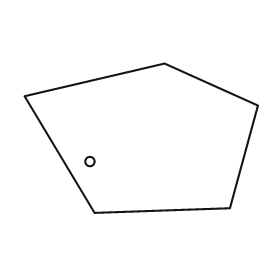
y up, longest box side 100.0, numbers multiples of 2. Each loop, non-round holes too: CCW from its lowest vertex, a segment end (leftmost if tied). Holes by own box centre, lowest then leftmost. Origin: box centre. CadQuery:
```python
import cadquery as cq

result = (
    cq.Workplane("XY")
    .moveTo(-20.0, -32.0)
    .lineTo(38.0, -30.0)
    .lineTo(50.0, 14.0)
    .lineTo(10.0, 32.0)
    .lineTo(-50.0, 18.0)
    .close()
    .moveTo(-22.0, -10.0)
    .circle(2.0)
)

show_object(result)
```